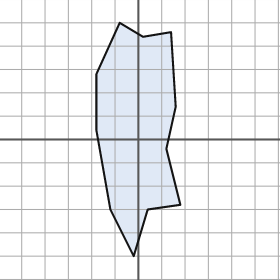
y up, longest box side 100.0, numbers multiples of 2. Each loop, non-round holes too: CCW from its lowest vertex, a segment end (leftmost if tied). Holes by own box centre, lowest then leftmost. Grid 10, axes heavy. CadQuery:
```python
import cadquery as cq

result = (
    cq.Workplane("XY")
    .moveTo(-2.0, -50.0)
    .lineTo(4.0, -30.0)
    .lineTo(18.0, -28.0)
    .lineTo(12.0, -4.0)
    .lineTo(16.0, 14.0)
    .lineTo(14.0, 46.0)
    .lineTo(2.0, 44.0)
    .lineTo(-8.0, 50.0)
    .lineTo(-18.0, 28.0)
    .lineTo(-18.0, 4.0)
    .lineTo(-12.0, -30.0)
    .close()
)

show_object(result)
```